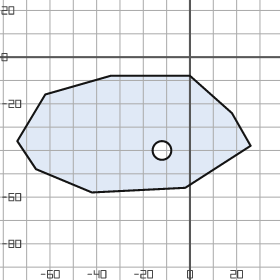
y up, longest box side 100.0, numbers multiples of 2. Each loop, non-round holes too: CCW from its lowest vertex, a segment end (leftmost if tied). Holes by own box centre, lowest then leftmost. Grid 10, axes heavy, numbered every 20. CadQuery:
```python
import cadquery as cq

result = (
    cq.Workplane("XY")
    .moveTo(-42.0, -58.0)
    .lineTo(-2.0, -56.0)
    .lineTo(26.0, -38.0)
    .lineTo(18.0, -24.0)
    .lineTo(0.0, -8.0)
    .lineTo(-34.0, -8.0)
    .lineTo(-62.0, -16.0)
    .lineTo(-74.0, -36.0)
    .lineTo(-66.0, -48.0)
    .close()
    .moveTo(-12.0, -40.0)
    .circle(4.0)
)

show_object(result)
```